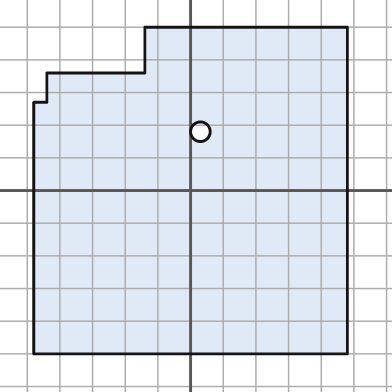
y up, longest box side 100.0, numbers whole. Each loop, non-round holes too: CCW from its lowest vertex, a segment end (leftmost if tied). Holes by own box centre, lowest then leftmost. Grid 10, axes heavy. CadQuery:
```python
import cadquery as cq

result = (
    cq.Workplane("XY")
    .moveTo(-48.0, -50.0)
    .lineTo(48.0, -50.0)
    .lineTo(48.0, 50.0)
    .lineTo(-14.0, 50.0)
    .lineTo(-14.0, 36.0)
    .lineTo(-44.0, 36.0)
    .lineTo(-44.0, 27.0)
    .lineTo(-48.0, 27.0)
    .close()
    .moveTo(3.0, 18.0)
    .circle(3.0)
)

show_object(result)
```